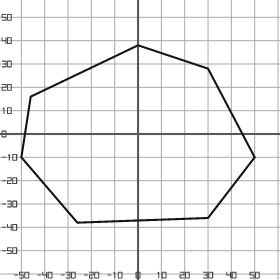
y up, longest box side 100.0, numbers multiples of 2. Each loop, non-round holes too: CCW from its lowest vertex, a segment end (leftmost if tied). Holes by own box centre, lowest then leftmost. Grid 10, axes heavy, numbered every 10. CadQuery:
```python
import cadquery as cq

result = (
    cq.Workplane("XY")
    .moveTo(-26.0, -38.0)
    .lineTo(30.0, -36.0)
    .lineTo(50.0, -10.0)
    .lineTo(30.0, 28.0)
    .lineTo(0.0, 38.0)
    .lineTo(-46.0, 16.0)
    .lineTo(-50.0, -10.0)
    .close()
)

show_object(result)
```